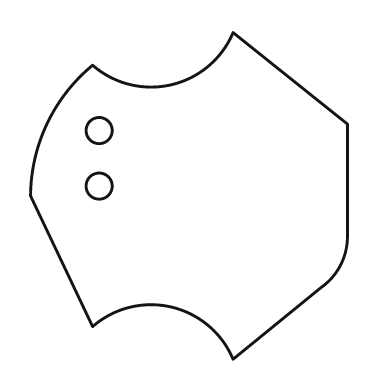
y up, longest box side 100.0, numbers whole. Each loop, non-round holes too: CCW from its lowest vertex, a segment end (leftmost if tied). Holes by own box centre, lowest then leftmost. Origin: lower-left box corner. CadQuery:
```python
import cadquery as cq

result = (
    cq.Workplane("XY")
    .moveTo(62.0, 0.0)
    .lineTo(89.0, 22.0)
    .threePointArc((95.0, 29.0), (97.0, 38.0))
    .lineTo(97.0, 72.0)
    .lineTo(62.0, 100.0)
    .threePointArc((43.0, 84.0), (19.0, 90.0))
    .threePointArc((5.0, 72.0), (0.0, 50.0))
    .lineTo(19.0, 10.0)
    .threePointArc((43.0, 16.0), (62.0, 0.0))
    .close()
    .moveTo(21.0, 53.0)
    .circle(4.0)
    .moveTo(21.0, 70.0)
    .circle(4.0)
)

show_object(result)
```